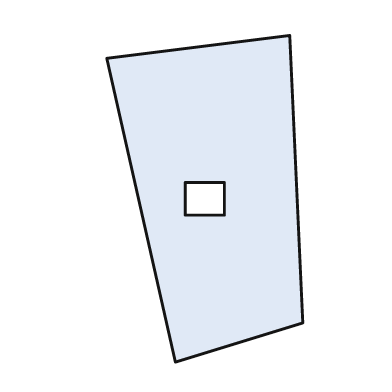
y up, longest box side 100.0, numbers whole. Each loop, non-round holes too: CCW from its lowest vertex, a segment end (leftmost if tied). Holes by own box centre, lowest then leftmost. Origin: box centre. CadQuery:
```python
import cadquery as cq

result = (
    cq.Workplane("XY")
    .moveTo(-9.0, -50.0)
    .lineTo(30.0, -38.0)
    .lineTo(26.0, 50.0)
    .lineTo(-30.0, 43.0)
    .close()
    .moveTo(-6.0, -5.0)
    .lineTo(6.0, -5.0)
    .lineTo(6.0, 5.0)
    .lineTo(-6.0, 5.0)
    .close()
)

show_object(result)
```